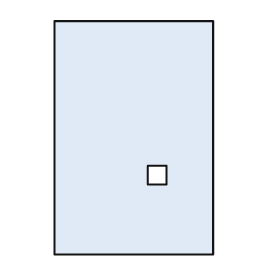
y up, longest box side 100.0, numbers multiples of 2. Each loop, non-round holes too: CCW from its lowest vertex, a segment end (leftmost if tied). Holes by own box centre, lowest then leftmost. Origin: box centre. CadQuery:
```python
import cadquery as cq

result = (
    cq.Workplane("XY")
    .moveTo(-34.0, -50.0)
    .lineTo(34.0, -50.0)
    .lineTo(34.0, 50.0)
    .lineTo(-34.0, 50.0)
    .close()
    .moveTo(6.0, -20.0)
    .lineTo(14.0, -20.0)
    .lineTo(14.0, -12.0)
    .lineTo(6.0, -12.0)
    .close()
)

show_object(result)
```